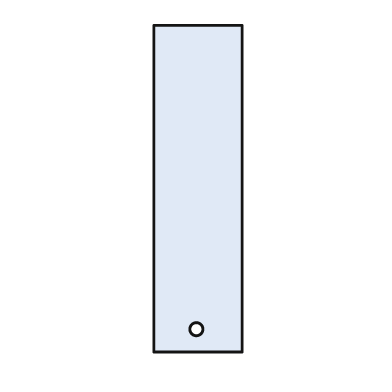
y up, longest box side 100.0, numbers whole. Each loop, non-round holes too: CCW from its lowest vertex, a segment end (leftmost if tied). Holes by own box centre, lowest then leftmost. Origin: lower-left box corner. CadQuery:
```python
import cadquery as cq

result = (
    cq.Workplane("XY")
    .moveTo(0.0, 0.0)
    .lineTo(27.0, 0.0)
    .lineTo(27.0, 100.0)
    .lineTo(0.0, 100.0)
    .close()
    .moveTo(13.0, 7.0)
    .circle(2.0)
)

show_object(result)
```